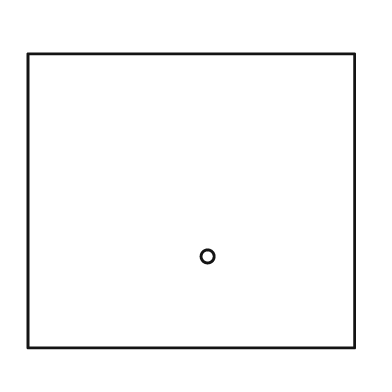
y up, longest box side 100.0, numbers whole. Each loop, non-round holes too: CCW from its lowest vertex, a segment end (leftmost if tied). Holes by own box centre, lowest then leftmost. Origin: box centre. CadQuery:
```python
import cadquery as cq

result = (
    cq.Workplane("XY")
    .moveTo(-50.0, -45.0)
    .lineTo(50.0, -45.0)
    .lineTo(50.0, 45.0)
    .lineTo(-50.0, 45.0)
    .close()
    .moveTo(5.0, -17.0)
    .circle(2.0)
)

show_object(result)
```